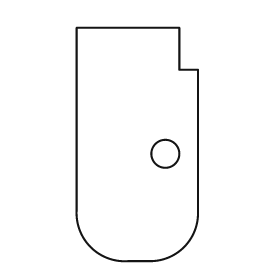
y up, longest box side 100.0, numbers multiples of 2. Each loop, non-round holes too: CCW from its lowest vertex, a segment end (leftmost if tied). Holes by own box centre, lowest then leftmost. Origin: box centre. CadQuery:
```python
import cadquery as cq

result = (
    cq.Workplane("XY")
    .moveTo(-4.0, -50.0)
    .lineTo(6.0, -50.0)
    .threePointArc((20.0, -44.0), (26.0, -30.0))
    .lineTo(26.0, 32.0)
    .lineTo(18.0, 32.0)
    .lineTo(18.0, 50.0)
    .lineTo(-26.0, 50.0)
    .lineTo(-26.0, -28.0)
    .threePointArc((-20.0, -44.0), (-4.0, -50.0))
    .close()
    .moveTo(12.0, -4.0)
    .circle(6.0)
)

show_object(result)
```